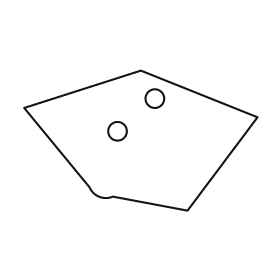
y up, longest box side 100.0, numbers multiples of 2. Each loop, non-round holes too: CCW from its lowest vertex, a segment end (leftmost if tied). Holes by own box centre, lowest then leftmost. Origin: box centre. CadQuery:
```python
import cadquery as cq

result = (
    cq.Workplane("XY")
    .moveTo(20.0, -30.0)
    .lineTo(50.0, 10.0)
    .lineTo(0.0, 30.0)
    .lineTo(-50.0, 14.0)
    .lineTo(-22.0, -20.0)
    .threePointArc((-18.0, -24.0), (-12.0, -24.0))
    .close()
    .moveTo(-10.0, 4.0)
    .circle(4.0)
    .moveTo(6.0, 18.0)
    .circle(4.0)
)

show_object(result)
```